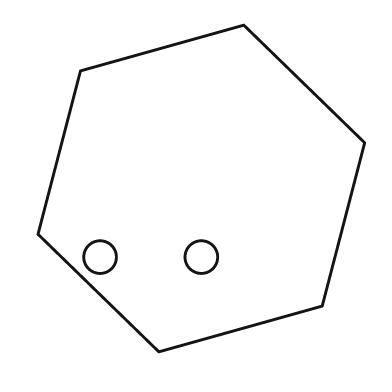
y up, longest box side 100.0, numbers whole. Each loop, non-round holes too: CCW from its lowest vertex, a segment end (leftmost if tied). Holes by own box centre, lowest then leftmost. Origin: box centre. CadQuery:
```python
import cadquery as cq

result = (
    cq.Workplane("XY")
    .moveTo(-13.0, -50.0)
    .lineTo(37.0, -36.0)
    .lineTo(50.0, 14.0)
    .lineTo(13.0, 50.0)
    .lineTo(-37.0, 36.0)
    .lineTo(-50.0, -14.0)
    .close()
    .moveTo(-31.0, -21.0)
    .circle(5.0)
    .moveTo(0.0, -21.0)
    .circle(5.0)
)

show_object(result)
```